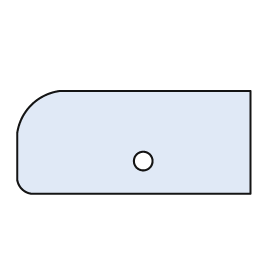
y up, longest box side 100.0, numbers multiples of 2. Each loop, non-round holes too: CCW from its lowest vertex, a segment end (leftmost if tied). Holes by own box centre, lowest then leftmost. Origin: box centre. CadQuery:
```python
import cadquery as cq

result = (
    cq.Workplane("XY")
    .moveTo(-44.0, -22.0)
    .lineTo(50.0, -22.0)
    .lineTo(50.0, 22.0)
    .lineTo(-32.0, 22.0)
    .threePointArc((-44.0, 16.0), (-50.0, 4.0))
    .lineTo(-50.0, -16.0)
    .threePointArc((-48.0, -20.0), (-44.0, -22.0))
    .close()
    .moveTo(4.0, -8.0)
    .circle(4.0)
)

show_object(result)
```